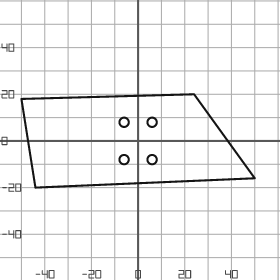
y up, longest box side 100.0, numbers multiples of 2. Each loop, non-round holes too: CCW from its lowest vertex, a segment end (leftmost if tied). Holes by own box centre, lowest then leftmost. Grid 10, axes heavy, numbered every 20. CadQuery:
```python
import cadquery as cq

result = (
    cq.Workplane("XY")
    .moveTo(-44.0, -20.0)
    .lineTo(50.0, -16.0)
    .lineTo(24.0, 20.0)
    .lineTo(-50.0, 18.0)
    .close()
    .moveTo(-6.0, -8.0)
    .circle(2.0)
    .moveTo(6.0, -8.0)
    .circle(2.0)
    .moveTo(-6.0, 8.0)
    .circle(2.0)
    .moveTo(6.0, 8.0)
    .circle(2.0)
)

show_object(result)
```